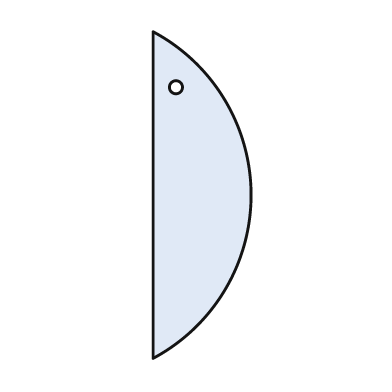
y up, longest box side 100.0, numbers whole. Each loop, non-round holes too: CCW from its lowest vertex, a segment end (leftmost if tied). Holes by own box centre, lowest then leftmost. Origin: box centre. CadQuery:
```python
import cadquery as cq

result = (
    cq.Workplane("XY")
    .moveTo(-15.0, -50.0)
    .threePointArc((15.0, 0.0), (-15.0, 50.0))
    .close()
    .moveTo(-8.0, 33.0)
    .circle(2.0)
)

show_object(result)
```